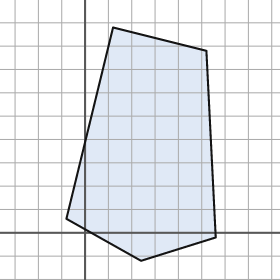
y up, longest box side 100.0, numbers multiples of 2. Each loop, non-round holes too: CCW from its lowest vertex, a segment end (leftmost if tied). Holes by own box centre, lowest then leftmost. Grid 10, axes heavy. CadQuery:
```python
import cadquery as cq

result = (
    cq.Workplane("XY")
    .moveTo(24.0, -12.0)
    .lineTo(56.0, -2.0)
    .lineTo(52.0, 78.0)
    .lineTo(12.0, 88.0)
    .lineTo(-8.0, 6.0)
    .close()
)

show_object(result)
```